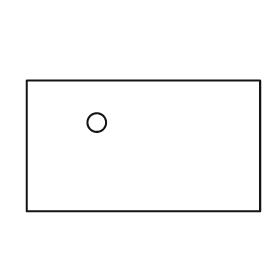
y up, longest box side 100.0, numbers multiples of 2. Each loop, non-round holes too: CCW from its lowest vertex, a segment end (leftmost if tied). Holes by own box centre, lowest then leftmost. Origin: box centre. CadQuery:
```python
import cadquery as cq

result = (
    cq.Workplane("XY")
    .moveTo(-50.0, -28.0)
    .lineTo(50.0, -28.0)
    .lineTo(50.0, 28.0)
    .lineTo(-50.0, 28.0)
    .close()
    .moveTo(-20.0, 10.0)
    .circle(4.0)
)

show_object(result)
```